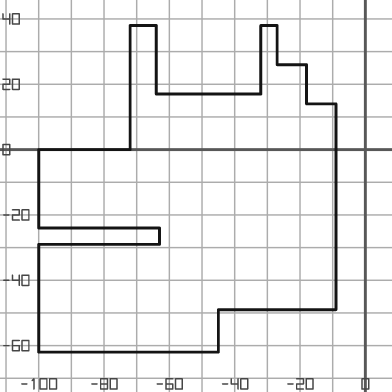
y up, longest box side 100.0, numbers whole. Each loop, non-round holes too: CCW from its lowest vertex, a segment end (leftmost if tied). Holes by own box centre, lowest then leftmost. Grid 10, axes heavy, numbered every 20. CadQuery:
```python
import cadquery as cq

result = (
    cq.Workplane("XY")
    .moveTo(-100.0, -62.0)
    .lineTo(-45.0, -62.0)
    .lineTo(-45.0, -49.0)
    .lineTo(-9.0, -49.0)
    .lineTo(-9.0, 14.0)
    .lineTo(-18.0, 14.0)
    .lineTo(-18.0, 26.0)
    .lineTo(-27.0, 26.0)
    .lineTo(-27.0, 38.0)
    .lineTo(-32.0, 38.0)
    .lineTo(-32.0, 17.0)
    .lineTo(-64.0, 17.0)
    .lineTo(-64.0, 38.0)
    .lineTo(-72.0, 38.0)
    .lineTo(-72.0, 0.0)
    .lineTo(-100.0, 0.0)
    .lineTo(-100.0, -24.0)
    .lineTo(-63.0, -24.0)
    .lineTo(-63.0, -29.0)
    .lineTo(-100.0, -29.0)
    .close()
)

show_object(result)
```